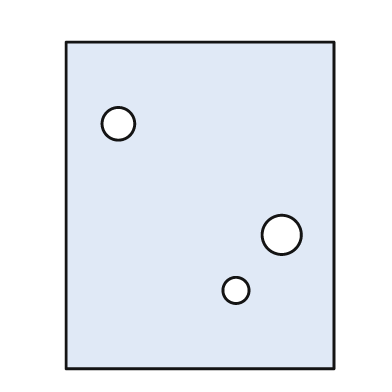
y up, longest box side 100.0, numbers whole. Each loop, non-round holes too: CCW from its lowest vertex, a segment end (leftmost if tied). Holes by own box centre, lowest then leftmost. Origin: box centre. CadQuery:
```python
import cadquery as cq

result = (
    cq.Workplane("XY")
    .moveTo(-41.0, -50.0)
    .lineTo(41.0, -50.0)
    .lineTo(41.0, 50.0)
    .lineTo(-41.0, 50.0)
    .close()
    .moveTo(11.0, -26.0)
    .circle(4.0)
    .moveTo(25.0, -9.0)
    .circle(6.0)
    .moveTo(-25.0, 25.0)
    .circle(5.0)
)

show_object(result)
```